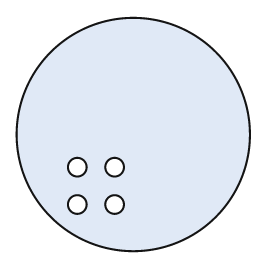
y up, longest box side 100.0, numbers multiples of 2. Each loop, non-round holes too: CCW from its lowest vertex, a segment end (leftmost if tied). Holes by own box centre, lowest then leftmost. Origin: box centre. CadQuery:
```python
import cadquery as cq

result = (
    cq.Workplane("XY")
    .moveTo(0.0, 0.0)
    .circle(50.0)
    .moveTo(-24.0, -30.0)
    .circle(4.0)
    .moveTo(-8.0, -30.0)
    .circle(4.0)
    .moveTo(-24.0, -14.0)
    .circle(4.0)
    .moveTo(-8.0, -14.0)
    .circle(4.0)
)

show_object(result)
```